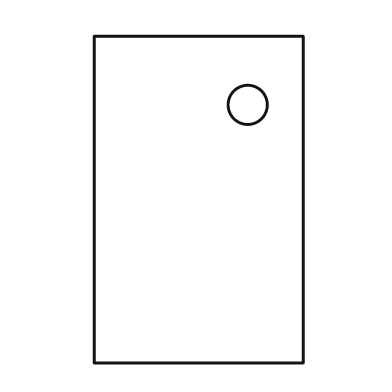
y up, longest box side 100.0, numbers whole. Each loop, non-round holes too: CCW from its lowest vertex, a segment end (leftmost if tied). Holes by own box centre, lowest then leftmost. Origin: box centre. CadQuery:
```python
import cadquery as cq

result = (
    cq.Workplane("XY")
    .moveTo(-32.0, -50.0)
    .lineTo(32.0, -50.0)
    .lineTo(32.0, 50.0)
    .lineTo(-32.0, 50.0)
    .close()
    .moveTo(15.0, 29.0)
    .circle(6.0)
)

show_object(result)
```